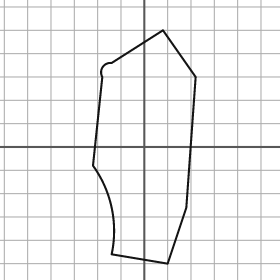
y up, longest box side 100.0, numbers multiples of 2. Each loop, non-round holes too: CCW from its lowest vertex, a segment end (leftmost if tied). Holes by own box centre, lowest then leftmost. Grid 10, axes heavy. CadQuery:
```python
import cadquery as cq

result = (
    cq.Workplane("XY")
    .moveTo(10.0, -50.0)
    .lineTo(18.0, -26.0)
    .lineTo(22.0, 30.0)
    .lineTo(8.0, 50.0)
    .lineTo(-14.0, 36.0)
    .threePointArc((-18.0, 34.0), (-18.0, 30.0))
    .lineTo(-22.0, -8.0)
    .threePointArc((-14.0, -26.0), (-14.0, -46.0))
    .close()
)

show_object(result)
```